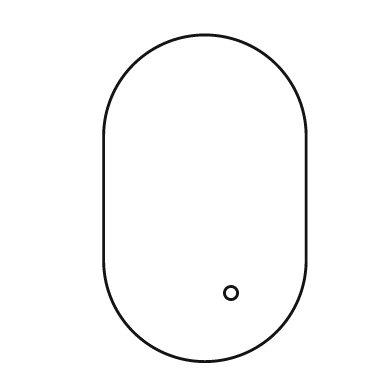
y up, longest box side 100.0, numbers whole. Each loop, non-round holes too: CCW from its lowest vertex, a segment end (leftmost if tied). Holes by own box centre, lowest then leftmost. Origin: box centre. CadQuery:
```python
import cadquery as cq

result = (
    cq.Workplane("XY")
    .moveTo(-31.0, -19.0)
    .threePointArc((0.0, -50.0), (31.0, -19.0))
    .lineTo(31.0, 19.0)
    .threePointArc((0.0, 50.0), (-31.0, 19.0))
    .close()
    .moveTo(8.0, -29.0)
    .circle(2.0)
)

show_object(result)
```